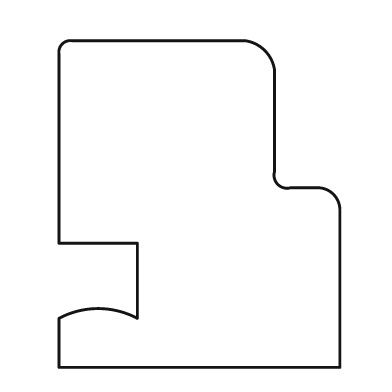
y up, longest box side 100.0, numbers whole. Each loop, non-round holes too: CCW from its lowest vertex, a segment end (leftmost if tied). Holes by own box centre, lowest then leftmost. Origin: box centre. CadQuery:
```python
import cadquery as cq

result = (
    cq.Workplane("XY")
    .moveTo(-43.0, -50.0)
    .lineTo(43.0, -50.0)
    .lineTo(43.0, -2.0)
    .threePointArc((41.0, 3.0), (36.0, 5.0))
    .lineTo(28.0, 5.0)
    .threePointArc((24.0, 6.0), (23.0, 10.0))
    .lineTo(23.0, 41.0)
    .threePointArc((20.0, 47.0), (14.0, 50.0))
    .lineTo(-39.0, 50.0)
    .threePointArc((-42.0, 49.0), (-43.0, 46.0))
    .lineTo(-43.0, -12.0)
    .lineTo(-19.0, -12.0)
    .lineTo(-19.0, -35.0)
    .threePointArc((-31.0, -32.0), (-43.0, -35.0))
    .close()
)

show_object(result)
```